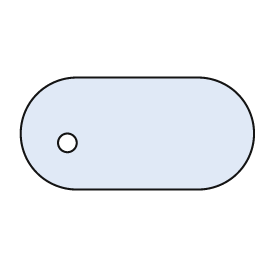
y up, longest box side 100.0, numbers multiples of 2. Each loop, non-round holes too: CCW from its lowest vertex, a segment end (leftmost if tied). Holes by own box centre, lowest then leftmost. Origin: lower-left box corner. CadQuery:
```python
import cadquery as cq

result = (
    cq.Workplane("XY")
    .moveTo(24.0, 0.0)
    .lineTo(76.0, 0.0)
    .threePointArc((100.0, 24.0), (76.0, 48.0))
    .lineTo(24.0, 48.0)
    .threePointArc((0.0, 24.0), (24.0, 0.0))
    .close()
    .moveTo(20.0, 20.0)
    .circle(4.0)
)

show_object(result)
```